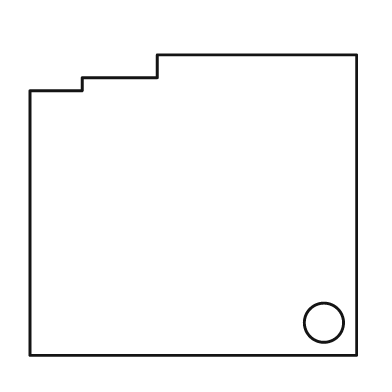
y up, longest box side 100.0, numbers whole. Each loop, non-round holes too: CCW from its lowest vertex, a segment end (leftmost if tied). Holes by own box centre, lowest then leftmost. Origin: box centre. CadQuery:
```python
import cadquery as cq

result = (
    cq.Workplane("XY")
    .moveTo(-50.0, -46.0)
    .lineTo(50.0, -46.0)
    .lineTo(50.0, 46.0)
    .lineTo(-11.0, 46.0)
    .lineTo(-11.0, 39.0)
    .lineTo(-34.0, 39.0)
    .lineTo(-34.0, 35.0)
    .lineTo(-50.0, 35.0)
    .close()
    .moveTo(40.0, -36.0)
    .circle(6.0)
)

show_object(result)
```